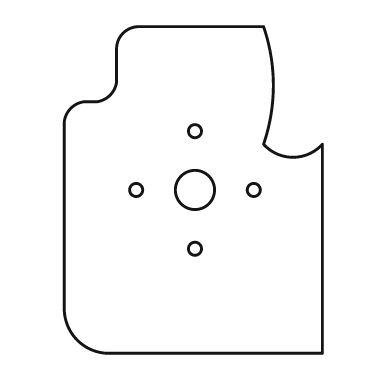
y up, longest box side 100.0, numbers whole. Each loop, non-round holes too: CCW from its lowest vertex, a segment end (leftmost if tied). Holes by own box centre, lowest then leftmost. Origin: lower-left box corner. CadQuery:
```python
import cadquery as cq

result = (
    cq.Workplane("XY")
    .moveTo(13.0, 0.0)
    .lineTo(79.0, 0.0)
    .lineTo(79.0, 64.0)
    .threePointArc((70.0, 60.0), (61.0, 64.0))
    .threePointArc((64.0, 82.0), (61.0, 100.0))
    .lineTo(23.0, 100.0)
    .threePointArc((18.0, 98.0), (16.0, 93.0))
    .lineTo(16.0, 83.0)
    .threePointArc((14.0, 79.0), (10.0, 77.0))
    .lineTo(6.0, 77.0)
    .threePointArc((2.0, 75.0), (0.0, 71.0))
    .lineTo(0.0, 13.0)
    .threePointArc((4.0, 4.0), (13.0, 0.0))
    .close()
    .moveTo(40.0, 32.0)
    .circle(2.0)
    .moveTo(22.0, 50.0)
    .circle(2.0)
    .moveTo(40.0, 50.0)
    .circle(6.0)
    .moveTo(58.0, 50.0)
    .circle(2.0)
    .moveTo(40.0, 68.0)
    .circle(2.0)
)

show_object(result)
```